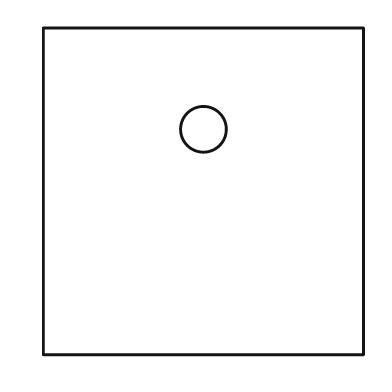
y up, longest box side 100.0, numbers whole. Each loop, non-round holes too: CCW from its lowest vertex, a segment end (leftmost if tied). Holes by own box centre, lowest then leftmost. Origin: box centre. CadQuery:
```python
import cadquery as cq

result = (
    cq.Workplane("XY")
    .moveTo(-49.0, -50.0)
    .lineTo(49.0, -50.0)
    .lineTo(49.0, 50.0)
    .lineTo(-49.0, 50.0)
    .close()
    .moveTo(0.0, 19.0)
    .circle(7.0)
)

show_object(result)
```